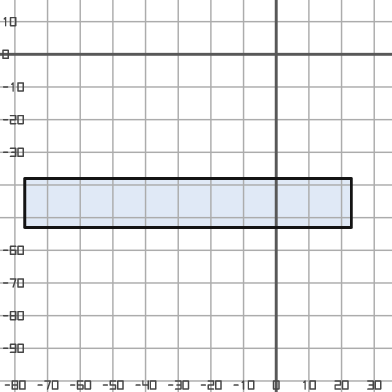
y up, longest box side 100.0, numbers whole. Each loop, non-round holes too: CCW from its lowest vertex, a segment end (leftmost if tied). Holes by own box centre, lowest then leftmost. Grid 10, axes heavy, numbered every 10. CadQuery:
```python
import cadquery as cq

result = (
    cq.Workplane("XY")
    .moveTo(-77.0, -53.0)
    .lineTo(23.0, -53.0)
    .lineTo(23.0, -38.0)
    .lineTo(-77.0, -38.0)
    .close()
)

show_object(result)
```